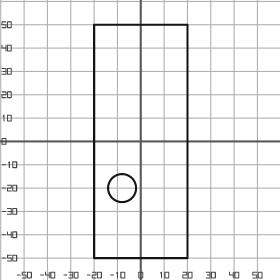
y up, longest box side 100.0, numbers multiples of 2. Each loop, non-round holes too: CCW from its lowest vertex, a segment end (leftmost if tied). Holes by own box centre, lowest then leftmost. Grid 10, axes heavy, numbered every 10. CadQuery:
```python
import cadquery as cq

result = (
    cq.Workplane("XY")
    .moveTo(-20.0, -50.0)
    .lineTo(20.0, -50.0)
    .lineTo(20.0, 50.0)
    .lineTo(-20.0, 50.0)
    .close()
    .moveTo(-8.0, -20.0)
    .circle(6.0)
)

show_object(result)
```